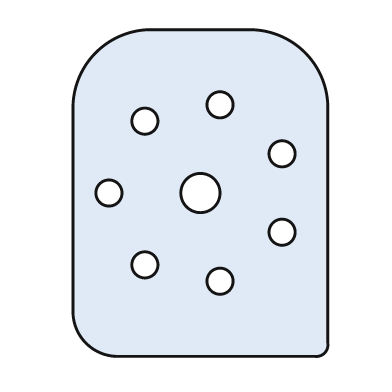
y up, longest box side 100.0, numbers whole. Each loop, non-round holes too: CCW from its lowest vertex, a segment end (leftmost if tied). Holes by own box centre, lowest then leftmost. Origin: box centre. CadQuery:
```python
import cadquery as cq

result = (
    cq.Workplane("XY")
    .moveTo(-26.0, -50.0)
    .lineTo(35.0, -50.0)
    .threePointArc((38.0, -49.0), (39.0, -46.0))
    .lineTo(39.0, 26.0)
    .threePointArc((32.0, 43.0), (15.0, 50.0))
    .lineTo(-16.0, 50.0)
    .threePointArc((-32.0, 43.0), (-39.0, 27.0))
    .lineTo(-39.0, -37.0)
    .threePointArc((-35.0, -46.0), (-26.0, -50.0))
    .close()
    .moveTo(6.0, -27.0)
    .circle(4.0)
    .moveTo(-17.0, -22.0)
    .circle(4.0)
    .moveTo(25.0, -12.0)
    .circle(4.0)
    .moveTo(-28.0, 0.0)
    .circle(4.0)
    .moveTo(0.0, 0.0)
    .circle(6.0)
    .moveTo(25.0, 12.0)
    .circle(4.0)
    .moveTo(-17.0, 22.0)
    .circle(4.0)
    .moveTo(6.0, 27.0)
    .circle(4.0)
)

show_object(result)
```